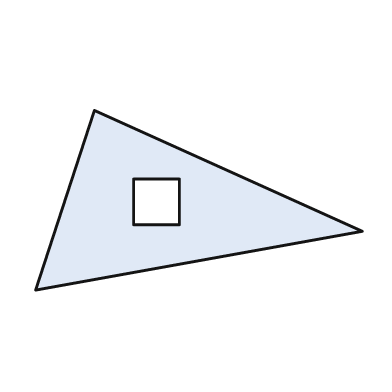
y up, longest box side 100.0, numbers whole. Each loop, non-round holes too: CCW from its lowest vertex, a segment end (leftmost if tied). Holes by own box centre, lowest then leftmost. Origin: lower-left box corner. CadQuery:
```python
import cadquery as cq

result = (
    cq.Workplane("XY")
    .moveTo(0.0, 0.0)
    .lineTo(100.0, 18.0)
    .lineTo(18.0, 55.0)
    .close()
    .moveTo(30.0, 20.0)
    .lineTo(44.0, 20.0)
    .lineTo(44.0, 34.0)
    .lineTo(30.0, 34.0)
    .close()
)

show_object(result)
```